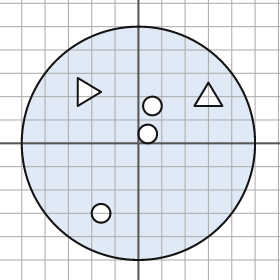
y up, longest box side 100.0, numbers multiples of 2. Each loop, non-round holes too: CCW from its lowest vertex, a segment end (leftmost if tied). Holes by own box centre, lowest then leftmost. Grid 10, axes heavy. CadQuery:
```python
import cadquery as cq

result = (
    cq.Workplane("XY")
    .moveTo(0.0, 0.0)
    .circle(50.0)
    .moveTo(-16.0, -30.0)
    .circle(4.0)
    .moveTo(4.0, 4.0)
    .circle(4.0)
    .moveTo(6.0, 16.0)
    .circle(4.0)
    .moveTo(24.0, 16.0)
    .lineTo(36.0, 16.0)
    .lineTo(30.0, 26.0)
    .close()
    .moveTo(-26.0, 16.0)
    .lineTo(-16.0, 22.0)
    .lineTo(-26.0, 28.0)
    .close()
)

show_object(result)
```